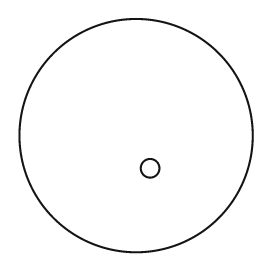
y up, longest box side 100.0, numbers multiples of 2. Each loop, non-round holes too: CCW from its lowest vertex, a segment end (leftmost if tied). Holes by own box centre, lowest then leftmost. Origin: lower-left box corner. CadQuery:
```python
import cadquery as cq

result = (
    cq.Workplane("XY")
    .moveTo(50.0, 50.0)
    .circle(50.0)
    .moveTo(56.0, 36.0)
    .circle(4.0)
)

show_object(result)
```